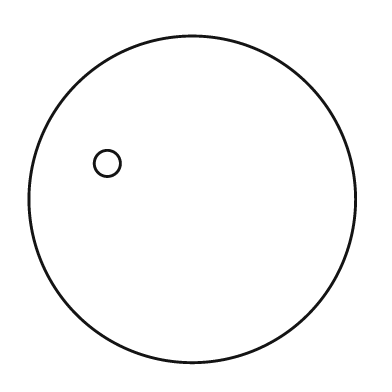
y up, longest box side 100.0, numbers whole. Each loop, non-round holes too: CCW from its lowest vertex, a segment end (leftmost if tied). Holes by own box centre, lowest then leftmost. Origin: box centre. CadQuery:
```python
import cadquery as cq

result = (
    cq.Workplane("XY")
    .moveTo(0.0, 0.0)
    .circle(50.0)
    .moveTo(-26.0, 11.0)
    .circle(4.0)
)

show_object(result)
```